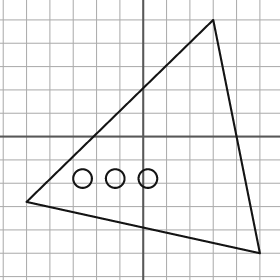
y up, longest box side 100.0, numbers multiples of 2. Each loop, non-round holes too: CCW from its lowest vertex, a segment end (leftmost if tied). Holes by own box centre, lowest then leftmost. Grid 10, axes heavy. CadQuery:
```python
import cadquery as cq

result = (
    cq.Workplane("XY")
    .moveTo(50.0, -50.0)
    .lineTo(30.0, 50.0)
    .lineTo(-50.0, -28.0)
    .close()
    .moveTo(-26.0, -18.0)
    .circle(4.0)
    .moveTo(-12.0, -18.0)
    .circle(4.0)
    .moveTo(2.0, -18.0)
    .circle(4.0)
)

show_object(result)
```